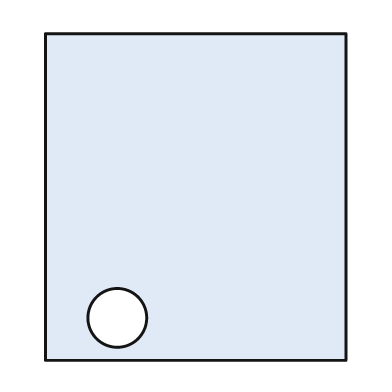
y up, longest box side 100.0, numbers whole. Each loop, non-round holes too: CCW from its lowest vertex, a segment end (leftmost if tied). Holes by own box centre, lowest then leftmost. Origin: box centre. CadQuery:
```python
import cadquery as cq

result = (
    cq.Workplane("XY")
    .moveTo(-46.0, -50.0)
    .lineTo(46.0, -50.0)
    .lineTo(46.0, 50.0)
    .lineTo(-46.0, 50.0)
    .close()
    .moveTo(-24.0, -37.0)
    .circle(9.0)
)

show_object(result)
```